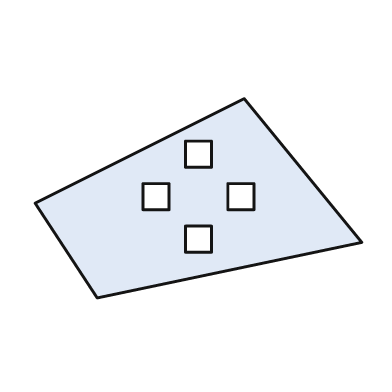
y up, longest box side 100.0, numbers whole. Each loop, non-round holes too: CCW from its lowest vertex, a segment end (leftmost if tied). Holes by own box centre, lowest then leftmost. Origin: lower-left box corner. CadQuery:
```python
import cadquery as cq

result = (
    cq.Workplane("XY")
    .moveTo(19.0, 0.0)
    .lineTo(100.0, 17.0)
    .lineTo(64.0, 61.0)
    .lineTo(0.0, 29.0)
    .close()
    .moveTo(46.0, 14.0)
    .lineTo(54.0, 14.0)
    .lineTo(54.0, 22.0)
    .lineTo(46.0, 22.0)
    .close()
    .moveTo(33.0, 27.0)
    .lineTo(41.0, 27.0)
    .lineTo(41.0, 35.0)
    .lineTo(33.0, 35.0)
    .close()
    .moveTo(59.0, 27.0)
    .lineTo(67.0, 27.0)
    .lineTo(67.0, 35.0)
    .lineTo(59.0, 35.0)
    .close()
    .moveTo(46.0, 40.0)
    .lineTo(54.0, 40.0)
    .lineTo(54.0, 48.0)
    .lineTo(46.0, 48.0)
    .close()
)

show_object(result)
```